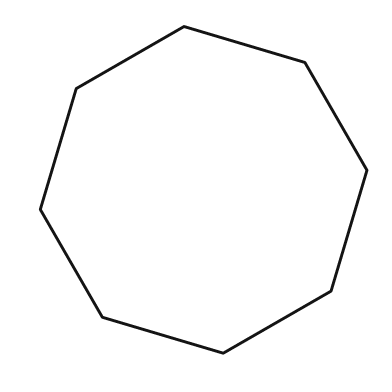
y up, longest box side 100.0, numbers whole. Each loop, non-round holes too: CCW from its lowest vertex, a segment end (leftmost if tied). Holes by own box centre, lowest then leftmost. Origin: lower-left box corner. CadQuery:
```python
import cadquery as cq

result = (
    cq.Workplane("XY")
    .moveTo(56.0, 0.0)
    .lineTo(89.0, 19.0)
    .lineTo(100.0, 56.0)
    .lineTo(81.0, 89.0)
    .lineTo(44.0, 100.0)
    .lineTo(11.0, 81.0)
    .lineTo(0.0, 44.0)
    .lineTo(19.0, 11.0)
    .close()
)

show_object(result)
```